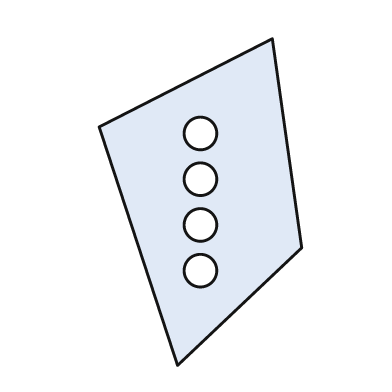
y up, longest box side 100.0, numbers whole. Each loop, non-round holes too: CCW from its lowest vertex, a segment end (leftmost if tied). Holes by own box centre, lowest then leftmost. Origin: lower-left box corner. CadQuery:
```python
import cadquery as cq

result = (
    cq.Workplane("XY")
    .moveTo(24.0, 0.0)
    .lineTo(62.0, 36.0)
    .lineTo(53.0, 100.0)
    .lineTo(0.0, 73.0)
    .close()
    .moveTo(31.0, 29.0)
    .circle(5.0)
    .moveTo(31.0, 43.0)
    .circle(5.0)
    .moveTo(31.0, 57.0)
    .circle(5.0)
    .moveTo(31.0, 71.0)
    .circle(5.0)
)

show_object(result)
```